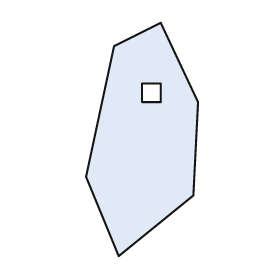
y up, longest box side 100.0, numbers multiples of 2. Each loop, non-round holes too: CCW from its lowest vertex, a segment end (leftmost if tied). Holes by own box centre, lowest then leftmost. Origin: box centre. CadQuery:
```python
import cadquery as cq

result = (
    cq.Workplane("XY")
    .moveTo(-10.0, -50.0)
    .lineTo(22.0, -24.0)
    .lineTo(24.0, 16.0)
    .lineTo(8.0, 50.0)
    .lineTo(-12.0, 40.0)
    .lineTo(-24.0, -16.0)
    .close()
    .moveTo(0.0, 16.0)
    .lineTo(8.0, 16.0)
    .lineTo(8.0, 24.0)
    .lineTo(0.0, 24.0)
    .close()
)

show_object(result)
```